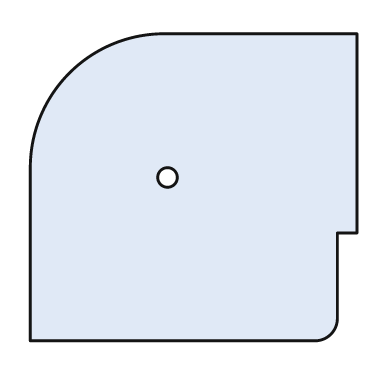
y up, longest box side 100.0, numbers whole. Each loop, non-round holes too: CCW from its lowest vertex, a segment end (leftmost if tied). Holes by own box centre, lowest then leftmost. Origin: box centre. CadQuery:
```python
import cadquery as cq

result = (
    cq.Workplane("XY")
    .moveTo(-50.0, -47.0)
    .lineTo(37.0, -47.0)
    .threePointArc((42.0, -45.0), (44.0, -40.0))
    .lineTo(44.0, -14.0)
    .lineTo(50.0, -14.0)
    .lineTo(50.0, 47.0)
    .lineTo(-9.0, 47.0)
    .threePointArc((-38.0, 35.0), (-50.0, 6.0))
    .close()
    .moveTo(-8.0, 3.0)
    .circle(3.0)
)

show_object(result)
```